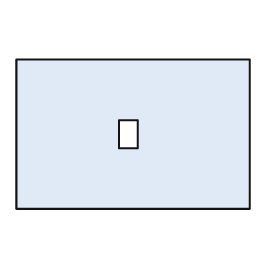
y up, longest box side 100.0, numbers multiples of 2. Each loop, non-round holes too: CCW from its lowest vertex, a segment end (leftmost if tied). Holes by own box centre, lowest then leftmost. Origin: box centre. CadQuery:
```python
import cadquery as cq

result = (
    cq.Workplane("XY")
    .moveTo(-50.0, -32.0)
    .lineTo(50.0, -32.0)
    .lineTo(50.0, 32.0)
    .lineTo(-50.0, 32.0)
    .close()
    .moveTo(-6.0, -6.0)
    .lineTo(2.0, -6.0)
    .lineTo(2.0, 6.0)
    .lineTo(-6.0, 6.0)
    .close()
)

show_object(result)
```